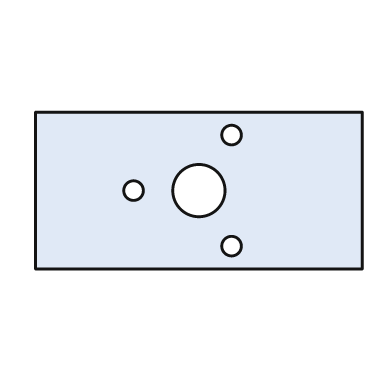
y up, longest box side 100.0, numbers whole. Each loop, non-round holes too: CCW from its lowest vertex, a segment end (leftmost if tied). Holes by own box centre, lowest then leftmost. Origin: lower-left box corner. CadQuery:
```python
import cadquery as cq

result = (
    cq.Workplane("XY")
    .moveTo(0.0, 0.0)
    .lineTo(100.0, 0.0)
    .lineTo(100.0, 48.0)
    .lineTo(0.0, 48.0)
    .close()
    .moveTo(60.0, 7.0)
    .circle(3.0)
    .moveTo(30.0, 24.0)
    .circle(3.0)
    .moveTo(50.0, 24.0)
    .circle(8.0)
    .moveTo(60.0, 41.0)
    .circle(3.0)
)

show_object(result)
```